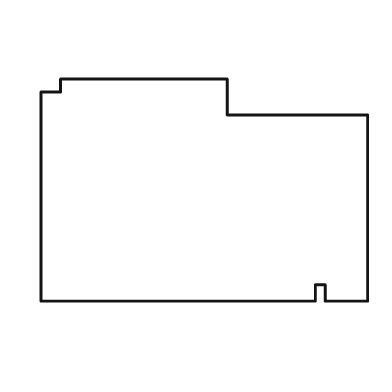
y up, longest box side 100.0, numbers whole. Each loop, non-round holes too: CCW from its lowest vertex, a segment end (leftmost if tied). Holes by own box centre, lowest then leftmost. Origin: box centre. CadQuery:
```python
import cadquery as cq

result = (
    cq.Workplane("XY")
    .moveTo(-50.0, -34.0)
    .lineTo(34.0, -34.0)
    .lineTo(34.0, -29.0)
    .lineTo(37.0, -29.0)
    .lineTo(37.0, -34.0)
    .lineTo(50.0, -34.0)
    .lineTo(50.0, 23.0)
    .lineTo(7.0, 23.0)
    .lineTo(7.0, 34.0)
    .lineTo(-44.0, 34.0)
    .lineTo(-44.0, 30.0)
    .lineTo(-50.0, 30.0)
    .close()
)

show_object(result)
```